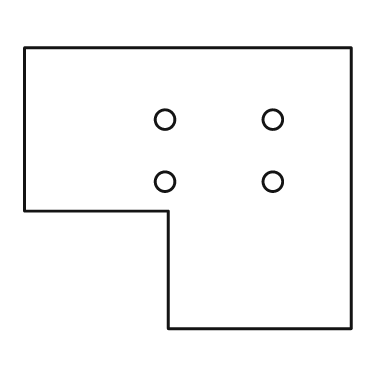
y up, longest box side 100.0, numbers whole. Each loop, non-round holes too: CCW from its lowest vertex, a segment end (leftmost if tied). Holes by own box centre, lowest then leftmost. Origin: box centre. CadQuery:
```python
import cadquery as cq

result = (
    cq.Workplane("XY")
    .moveTo(-6.0, -43.0)
    .lineTo(50.0, -43.0)
    .lineTo(50.0, 43.0)
    .lineTo(-50.0, 43.0)
    .lineTo(-50.0, -7.0)
    .lineTo(-6.0, -7.0)
    .close()
    .moveTo(-7.0, 2.0)
    .circle(3.0)
    .moveTo(26.0, 2.0)
    .circle(3.0)
    .moveTo(-7.0, 21.0)
    .circle(3.0)
    .moveTo(26.0, 21.0)
    .circle(3.0)
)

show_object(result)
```